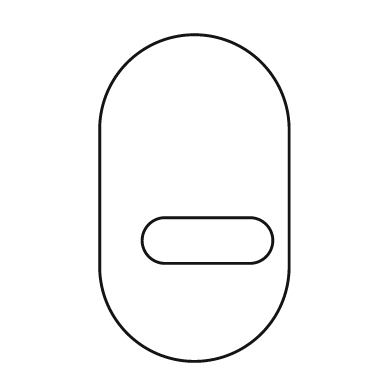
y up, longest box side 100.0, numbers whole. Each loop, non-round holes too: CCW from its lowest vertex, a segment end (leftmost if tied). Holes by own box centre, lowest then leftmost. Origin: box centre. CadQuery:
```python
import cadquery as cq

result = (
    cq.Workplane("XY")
    .moveTo(-29.0, -21.0)
    .threePointArc((0.0, -50.0), (29.0, -21.0))
    .lineTo(29.0, 21.0)
    .threePointArc((0.0, 50.0), (-29.0, 21.0))
    .close()
    .moveTo(-9.0, -20.0)
    .lineTo(17.0, -20.0)
    .threePointArc((24.0, -13.0), (17.0, -6.0))
    .lineTo(-9.0, -6.0)
    .threePointArc((-16.0, -13.0), (-9.0, -20.0))
    .close()
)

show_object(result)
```